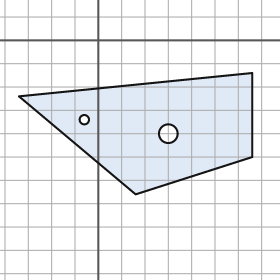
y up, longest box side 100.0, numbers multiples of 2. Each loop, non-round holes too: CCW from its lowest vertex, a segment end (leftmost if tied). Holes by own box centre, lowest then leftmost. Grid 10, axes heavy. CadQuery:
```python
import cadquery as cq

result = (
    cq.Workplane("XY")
    .moveTo(16.0, -66.0)
    .lineTo(66.0, -50.0)
    .lineTo(66.0, -14.0)
    .lineTo(-34.0, -24.0)
    .close()
    .moveTo(30.0, -40.0)
    .circle(4.0)
    .moveTo(-6.0, -34.0)
    .circle(2.0)
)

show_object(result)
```